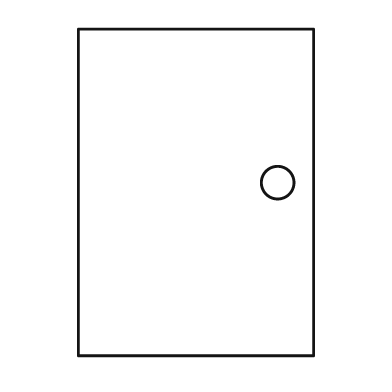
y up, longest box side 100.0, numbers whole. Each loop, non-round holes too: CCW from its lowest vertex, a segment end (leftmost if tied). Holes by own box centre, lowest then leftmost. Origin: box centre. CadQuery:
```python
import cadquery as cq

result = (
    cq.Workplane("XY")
    .moveTo(-36.0, -50.0)
    .lineTo(36.0, -50.0)
    .lineTo(36.0, 50.0)
    .lineTo(-36.0, 50.0)
    .close()
    .moveTo(25.0, 3.0)
    .circle(5.0)
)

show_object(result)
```